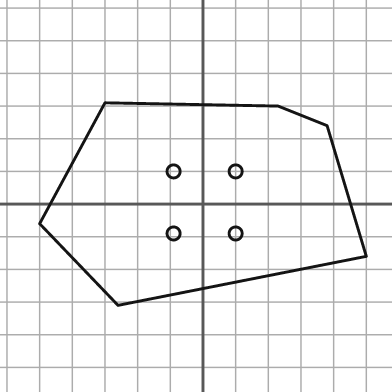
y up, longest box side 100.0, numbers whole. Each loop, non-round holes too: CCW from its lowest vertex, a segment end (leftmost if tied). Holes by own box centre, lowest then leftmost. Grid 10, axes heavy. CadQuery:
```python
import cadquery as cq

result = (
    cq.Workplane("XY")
    .moveTo(-26.0, -31.0)
    .lineTo(50.0, -16.0)
    .lineTo(38.0, 24.0)
    .lineTo(23.0, 30.0)
    .lineTo(-30.0, 31.0)
    .lineTo(-50.0, -6.0)
    .close()
    .moveTo(-9.0, -9.0)
    .circle(2.0)
    .moveTo(10.0, -9.0)
    .circle(2.0)
    .moveTo(-9.0, 10.0)
    .circle(2.0)
    .moveTo(10.0, 10.0)
    .circle(2.0)
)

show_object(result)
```